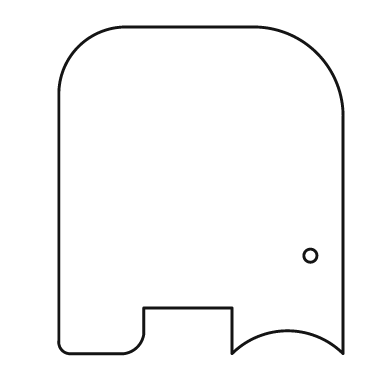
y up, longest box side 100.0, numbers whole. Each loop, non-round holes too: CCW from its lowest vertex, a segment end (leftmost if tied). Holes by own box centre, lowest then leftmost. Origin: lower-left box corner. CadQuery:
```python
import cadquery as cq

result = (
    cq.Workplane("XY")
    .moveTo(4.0, 0.0)
    .lineTo(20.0, 0.0)
    .threePointArc((24.0, 2.0), (26.0, 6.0))
    .lineTo(26.0, 14.0)
    .lineTo(53.0, 14.0)
    .lineTo(53.0, 0.0)
    .threePointArc((70.0, 7.0), (87.0, 0.0))
    .lineTo(87.0, 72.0)
    .threePointArc((79.0, 92.0), (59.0, 100.0))
    .lineTo(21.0, 100.0)
    .threePointArc((6.0, 94.0), (0.0, 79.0))
    .lineTo(0.0, 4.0)
    .threePointArc((1.0, 1.0), (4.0, 0.0))
    .close()
    .moveTo(77.0, 30.0)
    .circle(2.0)
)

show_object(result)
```